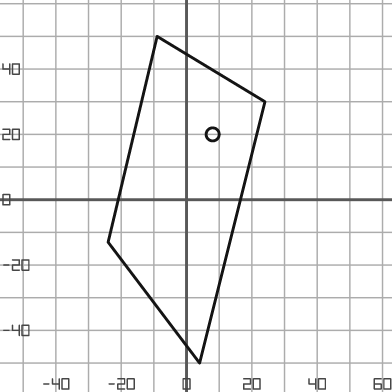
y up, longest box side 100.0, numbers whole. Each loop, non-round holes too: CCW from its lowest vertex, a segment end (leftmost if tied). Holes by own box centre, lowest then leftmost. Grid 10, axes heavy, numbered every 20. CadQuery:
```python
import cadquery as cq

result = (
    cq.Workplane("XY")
    .moveTo(4.0, -50.0)
    .lineTo(24.0, 30.0)
    .lineTo(-9.0, 50.0)
    .lineTo(-24.0, -13.0)
    .close()
    .moveTo(8.0, 20.0)
    .circle(2.0)
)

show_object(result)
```